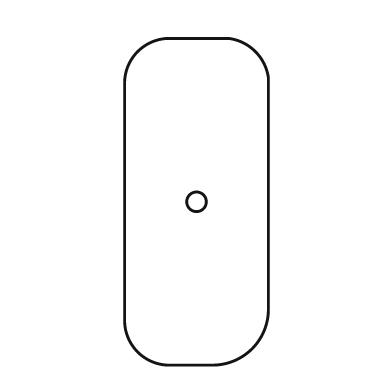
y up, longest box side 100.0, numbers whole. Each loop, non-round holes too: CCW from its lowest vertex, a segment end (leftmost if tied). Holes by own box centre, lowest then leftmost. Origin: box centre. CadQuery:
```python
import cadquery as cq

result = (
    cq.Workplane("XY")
    .moveTo(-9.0, -50.0)
    .lineTo(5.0, -50.0)
    .threePointArc((17.0, -45.0), (22.0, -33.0))
    .lineTo(22.0, 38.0)
    .threePointArc((18.0, 46.0), (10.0, 50.0))
    .lineTo(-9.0, 50.0)
    .threePointArc((-18.0, 46.0), (-22.0, 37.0))
    .lineTo(-22.0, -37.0)
    .threePointArc((-18.0, -46.0), (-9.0, -50.0))
    .close()
    .moveTo(0.0, 0.0)
    .circle(3.0)
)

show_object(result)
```